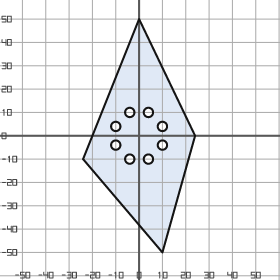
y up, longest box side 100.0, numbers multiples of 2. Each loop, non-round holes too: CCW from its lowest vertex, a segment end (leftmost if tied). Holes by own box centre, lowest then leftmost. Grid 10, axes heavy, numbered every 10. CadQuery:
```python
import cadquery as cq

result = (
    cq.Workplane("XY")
    .moveTo(10.0, -50.0)
    .lineTo(24.0, 0.0)
    .lineTo(0.0, 50.0)
    .lineTo(-24.0, -10.0)
    .close()
    .moveTo(-4.0, -10.0)
    .circle(2.0)
    .moveTo(4.0, -10.0)
    .circle(2.0)
    .moveTo(-10.0, -4.0)
    .circle(2.0)
    .moveTo(10.0, -4.0)
    .circle(2.0)
    .moveTo(-10.0, 4.0)
    .circle(2.0)
    .moveTo(10.0, 4.0)
    .circle(2.0)
    .moveTo(-4.0, 10.0)
    .circle(2.0)
    .moveTo(4.0, 10.0)
    .circle(2.0)
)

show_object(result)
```